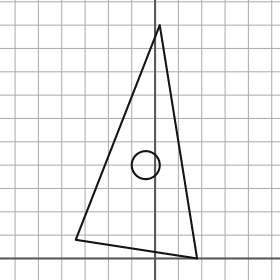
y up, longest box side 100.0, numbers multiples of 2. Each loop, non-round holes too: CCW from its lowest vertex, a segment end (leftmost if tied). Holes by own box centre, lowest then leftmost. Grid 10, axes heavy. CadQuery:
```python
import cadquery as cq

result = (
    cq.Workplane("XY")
    .moveTo(18.0, 0.0)
    .lineTo(2.0, 100.0)
    .lineTo(-34.0, 8.0)
    .close()
    .moveTo(-4.0, 40.0)
    .circle(6.0)
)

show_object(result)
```